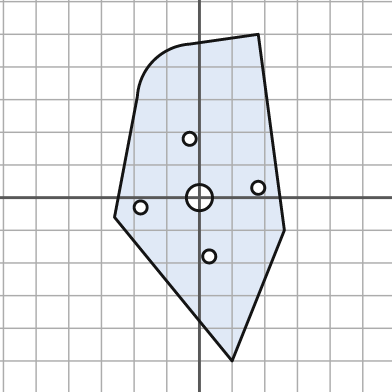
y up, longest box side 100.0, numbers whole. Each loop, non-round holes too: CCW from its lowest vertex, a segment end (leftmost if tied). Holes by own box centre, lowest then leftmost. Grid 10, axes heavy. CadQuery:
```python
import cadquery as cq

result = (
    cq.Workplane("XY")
    .moveTo(10.0, -50.0)
    .lineTo(26.0, -10.0)
    .lineTo(18.0, 50.0)
    .lineTo(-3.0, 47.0)
    .threePointArc((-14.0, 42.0), (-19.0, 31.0))
    .lineTo(-26.0, -6.0)
    .close()
    .moveTo(3.0, -18.0)
    .circle(2.0)
    .moveTo(-18.0, -3.0)
    .circle(2.0)
    .moveTo(0.0, 0.0)
    .circle(4.0)
    .moveTo(18.0, 3.0)
    .circle(2.0)
    .moveTo(-3.0, 18.0)
    .circle(2.0)
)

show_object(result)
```